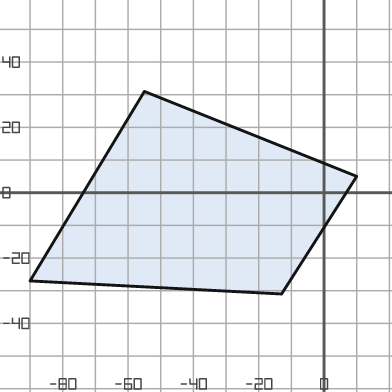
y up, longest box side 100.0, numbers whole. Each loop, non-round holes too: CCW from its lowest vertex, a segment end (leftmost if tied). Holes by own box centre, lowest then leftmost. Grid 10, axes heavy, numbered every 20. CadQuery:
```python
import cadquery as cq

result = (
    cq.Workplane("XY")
    .moveTo(-13.0, -31.0)
    .lineTo(10.0, 5.0)
    .lineTo(-55.0, 31.0)
    .lineTo(-90.0, -27.0)
    .close()
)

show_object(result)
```